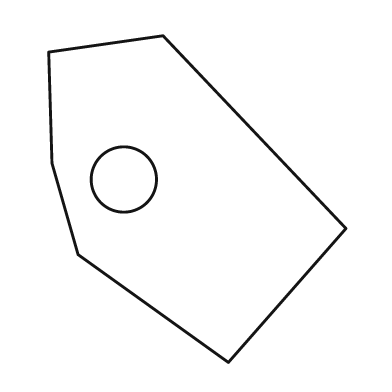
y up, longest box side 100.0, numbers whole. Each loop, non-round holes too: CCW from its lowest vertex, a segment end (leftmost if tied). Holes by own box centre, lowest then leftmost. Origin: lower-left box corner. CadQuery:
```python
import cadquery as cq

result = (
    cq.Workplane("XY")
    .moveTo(55.0, 0.0)
    .lineTo(91.0, 41.0)
    .lineTo(35.0, 100.0)
    .lineTo(0.0, 95.0)
    .lineTo(1.0, 61.0)
    .lineTo(9.0, 33.0)
    .close()
    .moveTo(23.0, 56.0)
    .circle(10.0)
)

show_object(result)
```